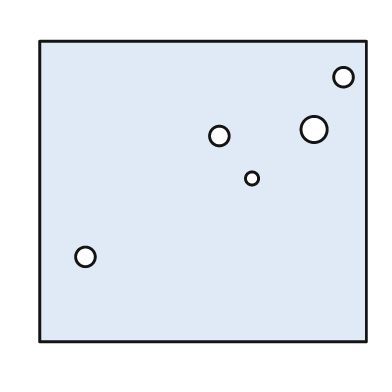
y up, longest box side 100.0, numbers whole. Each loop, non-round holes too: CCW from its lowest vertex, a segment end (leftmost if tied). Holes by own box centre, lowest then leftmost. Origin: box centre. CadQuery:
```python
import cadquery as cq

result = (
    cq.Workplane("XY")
    .moveTo(-50.0, -46.0)
    .lineTo(50.0, -46.0)
    .lineTo(50.0, 46.0)
    .lineTo(-50.0, 46.0)
    .close()
    .moveTo(-36.0, -20.0)
    .circle(3.0)
    .moveTo(15.0, 4.0)
    .circle(2.0)
    .moveTo(5.0, 17.0)
    .circle(3.0)
    .moveTo(34.0, 19.0)
    .circle(4.0)
    .moveTo(43.0, 35.0)
    .circle(3.0)
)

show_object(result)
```